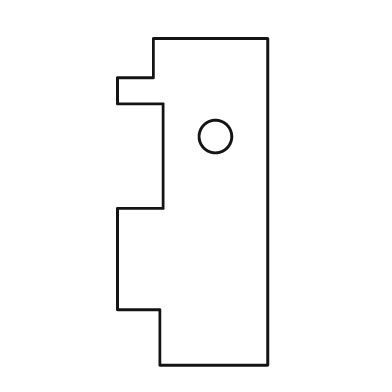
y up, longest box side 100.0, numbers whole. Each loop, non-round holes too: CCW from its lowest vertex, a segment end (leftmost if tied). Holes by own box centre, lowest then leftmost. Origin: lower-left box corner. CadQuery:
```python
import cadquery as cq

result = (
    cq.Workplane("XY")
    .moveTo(13.0, 0.0)
    .lineTo(46.0, 0.0)
    .lineTo(46.0, 100.0)
    .lineTo(11.0, 100.0)
    .lineTo(11.0, 88.0)
    .lineTo(0.0, 88.0)
    .lineTo(0.0, 80.0)
    .lineTo(14.0, 80.0)
    .lineTo(14.0, 48.0)
    .lineTo(0.0, 48.0)
    .lineTo(0.0, 17.0)
    .lineTo(13.0, 17.0)
    .close()
    .moveTo(30.0, 70.0)
    .circle(5.0)
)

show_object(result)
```